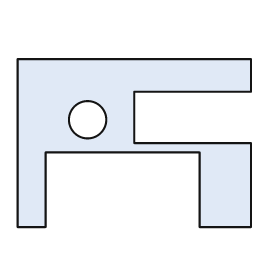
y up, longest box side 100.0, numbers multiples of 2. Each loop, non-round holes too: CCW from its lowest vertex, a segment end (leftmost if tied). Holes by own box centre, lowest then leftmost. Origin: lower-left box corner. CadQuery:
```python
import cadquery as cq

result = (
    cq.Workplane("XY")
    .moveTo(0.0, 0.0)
    .lineTo(12.0, 0.0)
    .lineTo(12.0, 32.0)
    .lineTo(78.0, 32.0)
    .lineTo(78.0, 0.0)
    .lineTo(100.0, 0.0)
    .lineTo(100.0, 36.0)
    .lineTo(50.0, 36.0)
    .lineTo(50.0, 58.0)
    .lineTo(100.0, 58.0)
    .lineTo(100.0, 72.0)
    .lineTo(0.0, 72.0)
    .close()
    .moveTo(30.0, 46.0)
    .circle(8.0)
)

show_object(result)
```